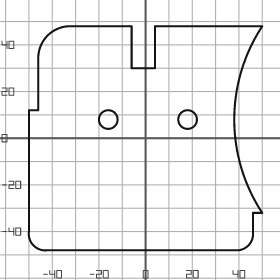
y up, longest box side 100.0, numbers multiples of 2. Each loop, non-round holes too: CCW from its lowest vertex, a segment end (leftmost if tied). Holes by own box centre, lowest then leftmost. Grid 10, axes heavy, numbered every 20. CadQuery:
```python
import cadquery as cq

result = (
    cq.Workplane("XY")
    .moveTo(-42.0, -48.0)
    .lineTo(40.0, -48.0)
    .threePointArc((44.0, -46.0), (46.0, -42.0))
    .lineTo(46.0, -32.0)
    .lineTo(50.0, -32.0)
    .threePointArc((38.0, 8.0), (50.0, 48.0))
    .lineTo(4.0, 48.0)
    .lineTo(4.0, 30.0)
    .lineTo(-6.0, 30.0)
    .lineTo(-6.0, 48.0)
    .lineTo(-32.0, 48.0)
    .threePointArc((-42.0, 44.0), (-46.0, 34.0))
    .lineTo(-46.0, 12.0)
    .lineTo(-50.0, 12.0)
    .lineTo(-50.0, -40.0)
    .threePointArc((-48.0, -46.0), (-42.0, -48.0))
    .close()
    .moveTo(-16.0, 8.0)
    .circle(4.0)
    .moveTo(18.0, 8.0)
    .circle(4.0)
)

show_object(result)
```